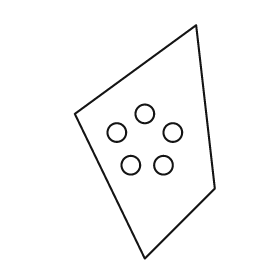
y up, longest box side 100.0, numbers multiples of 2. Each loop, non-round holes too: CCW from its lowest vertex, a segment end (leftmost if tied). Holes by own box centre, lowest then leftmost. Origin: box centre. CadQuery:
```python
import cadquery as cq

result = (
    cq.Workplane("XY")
    .moveTo(0.0, -50.0)
    .lineTo(30.0, -20.0)
    .lineTo(22.0, 50.0)
    .lineTo(-30.0, 12.0)
    .close()
    .moveTo(-6.0, -10.0)
    .circle(4.0)
    .moveTo(8.0, -10.0)
    .circle(4.0)
    .moveTo(-12.0, 4.0)
    .circle(4.0)
    .moveTo(12.0, 4.0)
    .circle(4.0)
    .moveTo(0.0, 12.0)
    .circle(4.0)
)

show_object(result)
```